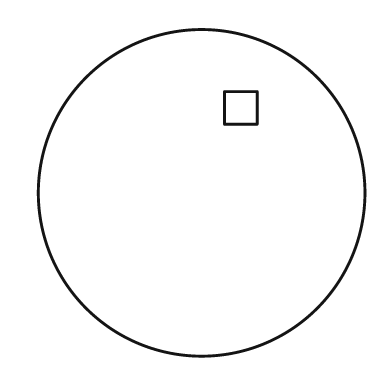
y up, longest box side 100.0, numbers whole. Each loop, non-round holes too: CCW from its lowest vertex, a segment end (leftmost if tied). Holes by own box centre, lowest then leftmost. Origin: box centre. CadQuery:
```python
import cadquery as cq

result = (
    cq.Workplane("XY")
    .moveTo(0.0, 0.0)
    .circle(50.0)
    .moveTo(7.0, 21.0)
    .lineTo(17.0, 21.0)
    .lineTo(17.0, 31.0)
    .lineTo(7.0, 31.0)
    .close()
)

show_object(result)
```